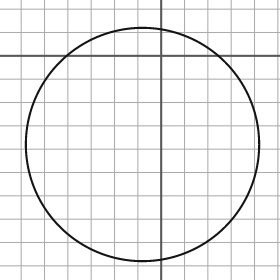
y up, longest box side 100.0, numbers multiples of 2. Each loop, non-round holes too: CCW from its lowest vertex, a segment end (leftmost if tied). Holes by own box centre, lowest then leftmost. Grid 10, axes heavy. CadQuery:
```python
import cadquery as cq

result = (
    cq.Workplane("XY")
    .moveTo(-8.0, -38.0)
    .circle(50.0)
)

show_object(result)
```